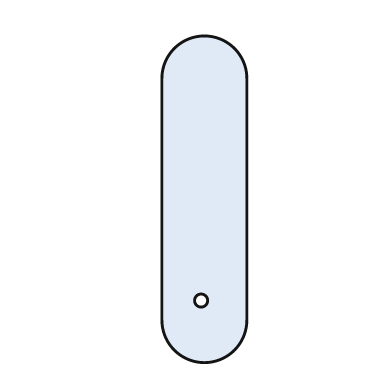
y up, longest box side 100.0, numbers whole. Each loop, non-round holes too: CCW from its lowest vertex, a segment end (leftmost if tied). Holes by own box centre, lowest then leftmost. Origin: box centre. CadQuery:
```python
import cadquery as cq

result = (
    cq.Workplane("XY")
    .moveTo(-13.0, -37.0)
    .threePointArc((0.0, -50.0), (13.0, -37.0))
    .lineTo(13.0, 37.0)
    .threePointArc((0.0, 50.0), (-13.0, 37.0))
    .close()
    .moveTo(-1.0, -31.0)
    .circle(2.0)
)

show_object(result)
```